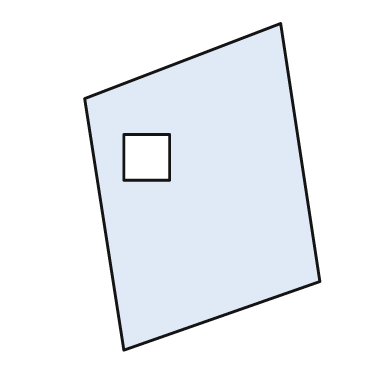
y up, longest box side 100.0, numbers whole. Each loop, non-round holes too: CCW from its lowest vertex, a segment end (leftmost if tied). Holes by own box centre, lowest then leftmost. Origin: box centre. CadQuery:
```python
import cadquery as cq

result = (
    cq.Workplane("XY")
    .moveTo(-24.0, -50.0)
    .lineTo(36.0, -29.0)
    .lineTo(24.0, 50.0)
    .lineTo(-36.0, 27.0)
    .close()
    .moveTo(-24.0, 2.0)
    .lineTo(-10.0, 2.0)
    .lineTo(-10.0, 16.0)
    .lineTo(-24.0, 16.0)
    .close()
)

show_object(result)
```